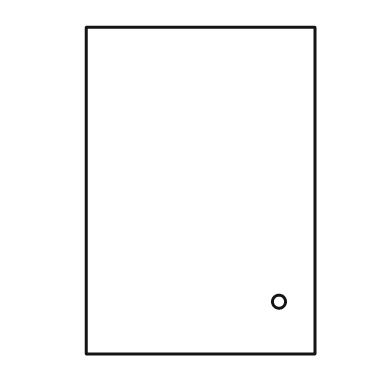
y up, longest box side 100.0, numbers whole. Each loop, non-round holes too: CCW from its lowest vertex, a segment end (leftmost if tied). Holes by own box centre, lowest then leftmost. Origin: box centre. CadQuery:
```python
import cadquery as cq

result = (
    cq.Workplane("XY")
    .moveTo(-35.0, -50.0)
    .lineTo(35.0, -50.0)
    .lineTo(35.0, 50.0)
    .lineTo(-35.0, 50.0)
    .close()
    .moveTo(24.0, -34.0)
    .circle(2.0)
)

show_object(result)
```